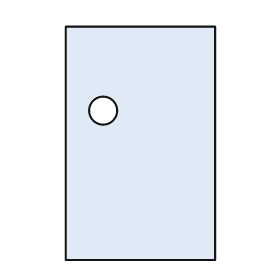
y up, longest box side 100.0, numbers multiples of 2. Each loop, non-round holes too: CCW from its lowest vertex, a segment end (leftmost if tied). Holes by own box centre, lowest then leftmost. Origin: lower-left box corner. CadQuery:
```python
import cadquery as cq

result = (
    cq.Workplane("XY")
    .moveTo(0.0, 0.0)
    .lineTo(64.0, 0.0)
    .lineTo(64.0, 100.0)
    .lineTo(0.0, 100.0)
    .close()
    .moveTo(16.0, 64.0)
    .circle(6.0)
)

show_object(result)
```